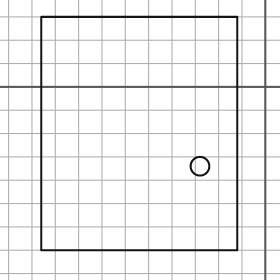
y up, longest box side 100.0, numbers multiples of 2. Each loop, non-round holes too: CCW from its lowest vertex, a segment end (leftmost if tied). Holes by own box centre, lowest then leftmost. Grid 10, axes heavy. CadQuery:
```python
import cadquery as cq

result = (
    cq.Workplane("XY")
    .moveTo(-96.0, -70.0)
    .lineTo(-12.0, -70.0)
    .lineTo(-12.0, 30.0)
    .lineTo(-96.0, 30.0)
    .close()
    .moveTo(-28.0, -34.0)
    .circle(4.0)
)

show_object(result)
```